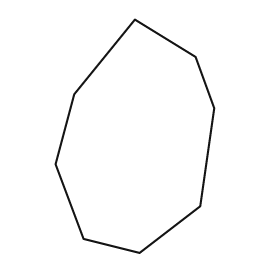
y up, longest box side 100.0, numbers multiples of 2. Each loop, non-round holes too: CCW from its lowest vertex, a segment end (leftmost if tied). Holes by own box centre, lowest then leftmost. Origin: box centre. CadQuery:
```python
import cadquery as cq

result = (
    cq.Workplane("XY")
    .moveTo(2.0, -50.0)
    .lineTo(28.0, -30.0)
    .lineTo(34.0, 12.0)
    .lineTo(26.0, 34.0)
    .lineTo(0.0, 50.0)
    .lineTo(-26.0, 18.0)
    .lineTo(-34.0, -12.0)
    .lineTo(-22.0, -44.0)
    .close()
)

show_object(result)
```